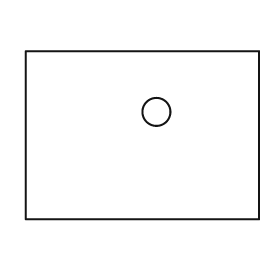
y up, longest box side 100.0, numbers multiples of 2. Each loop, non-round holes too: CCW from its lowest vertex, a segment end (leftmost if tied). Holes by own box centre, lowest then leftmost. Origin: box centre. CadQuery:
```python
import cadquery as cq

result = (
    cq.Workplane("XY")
    .moveTo(-50.0, -36.0)
    .lineTo(50.0, -36.0)
    .lineTo(50.0, 36.0)
    .lineTo(-50.0, 36.0)
    .close()
    .moveTo(6.0, 10.0)
    .circle(6.0)
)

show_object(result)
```